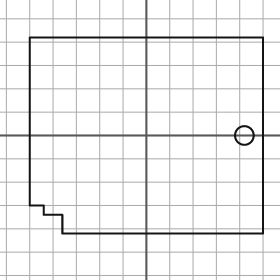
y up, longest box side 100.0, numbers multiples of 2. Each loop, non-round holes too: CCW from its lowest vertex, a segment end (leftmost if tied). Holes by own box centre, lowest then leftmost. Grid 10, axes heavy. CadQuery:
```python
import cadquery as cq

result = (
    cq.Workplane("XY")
    .moveTo(-36.0, -42.0)
    .lineTo(50.0, -42.0)
    .lineTo(50.0, 42.0)
    .lineTo(-50.0, 42.0)
    .lineTo(-50.0, -30.0)
    .lineTo(-44.0, -30.0)
    .lineTo(-44.0, -34.0)
    .lineTo(-36.0, -34.0)
    .close()
    .moveTo(42.0, 0.0)
    .circle(4.0)
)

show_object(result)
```